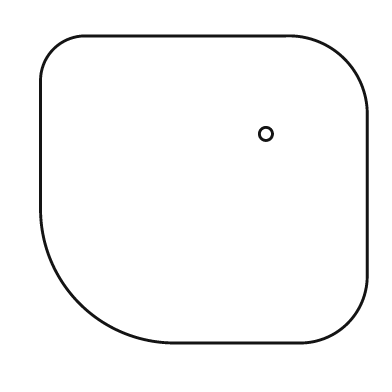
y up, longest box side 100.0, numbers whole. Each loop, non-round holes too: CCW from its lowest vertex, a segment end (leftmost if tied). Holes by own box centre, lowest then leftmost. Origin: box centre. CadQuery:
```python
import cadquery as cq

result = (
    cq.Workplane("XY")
    .moveTo(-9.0, -47.0)
    .lineTo(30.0, -47.0)
    .threePointArc((44.0, -41.0), (50.0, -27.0))
    .lineTo(50.0, 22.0)
    .threePointArc((43.0, 40.0), (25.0, 47.0))
    .lineTo(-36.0, 47.0)
    .threePointArc((-46.0, 43.0), (-50.0, 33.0))
    .lineTo(-50.0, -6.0)
    .threePointArc((-38.0, -35.0), (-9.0, -47.0))
    .close()
    .moveTo(19.0, 17.0)
    .circle(2.0)
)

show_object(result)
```